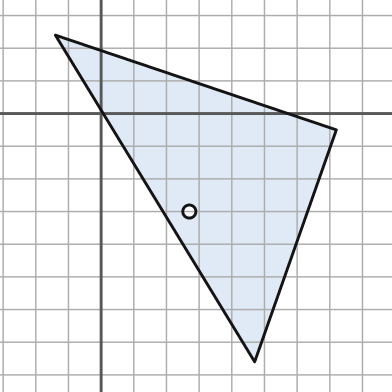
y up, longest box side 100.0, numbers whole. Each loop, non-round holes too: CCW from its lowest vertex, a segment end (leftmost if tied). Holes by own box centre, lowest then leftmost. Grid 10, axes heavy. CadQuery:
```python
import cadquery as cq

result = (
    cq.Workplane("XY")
    .moveTo(47.0, -76.0)
    .lineTo(72.0, -5.0)
    .lineTo(-14.0, 24.0)
    .close()
    .moveTo(27.0, -30.0)
    .circle(2.0)
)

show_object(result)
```